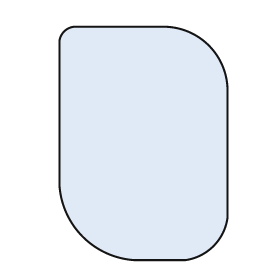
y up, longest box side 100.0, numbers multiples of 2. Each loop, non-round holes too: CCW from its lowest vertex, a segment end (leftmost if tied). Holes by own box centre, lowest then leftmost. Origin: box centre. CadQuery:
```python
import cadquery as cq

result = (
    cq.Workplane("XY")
    .moveTo(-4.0, -50.0)
    .lineTo(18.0, -50.0)
    .threePointArc((30.0, -44.0), (36.0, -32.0))
    .lineTo(36.0, 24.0)
    .threePointArc((28.0, 42.0), (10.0, 50.0))
    .lineTo(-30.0, 50.0)
    .threePointArc((-34.0, 48.0), (-36.0, 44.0))
    .lineTo(-36.0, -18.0)
    .threePointArc((-26.0, -40.0), (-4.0, -50.0))
    .close()
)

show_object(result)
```